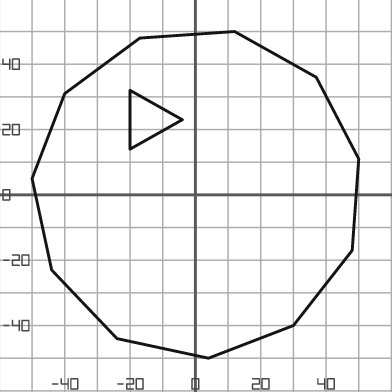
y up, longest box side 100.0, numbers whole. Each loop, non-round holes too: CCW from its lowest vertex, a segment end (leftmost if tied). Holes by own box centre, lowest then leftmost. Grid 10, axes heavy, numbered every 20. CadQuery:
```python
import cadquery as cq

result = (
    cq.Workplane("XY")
    .moveTo(4.0, -50.0)
    .lineTo(30.0, -40.0)
    .lineTo(48.0, -17.0)
    .lineTo(50.0, 11.0)
    .lineTo(37.0, 36.0)
    .lineTo(12.0, 50.0)
    .lineTo(-17.0, 48.0)
    .lineTo(-40.0, 31.0)
    .lineTo(-50.0, 5.0)
    .lineTo(-44.0, -23.0)
    .lineTo(-24.0, -44.0)
    .close()
    .moveTo(-20.0, 14.0)
    .lineTo(-4.0, 23.0)
    .lineTo(-20.0, 32.0)
    .close()
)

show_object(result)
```